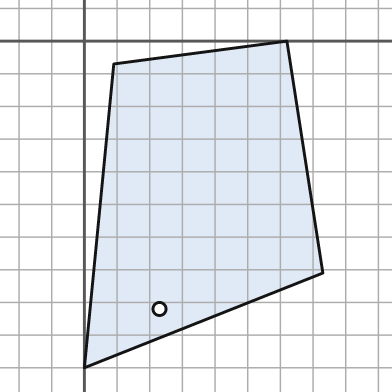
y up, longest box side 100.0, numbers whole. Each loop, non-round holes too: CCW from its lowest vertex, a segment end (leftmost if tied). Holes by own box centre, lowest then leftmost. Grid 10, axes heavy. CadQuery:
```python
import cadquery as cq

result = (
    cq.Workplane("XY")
    .moveTo(0.0, -100.0)
    .lineTo(73.0, -71.0)
    .lineTo(62.0, 0.0)
    .lineTo(9.0, -7.0)
    .close()
    .moveTo(23.0, -82.0)
    .circle(2.0)
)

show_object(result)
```